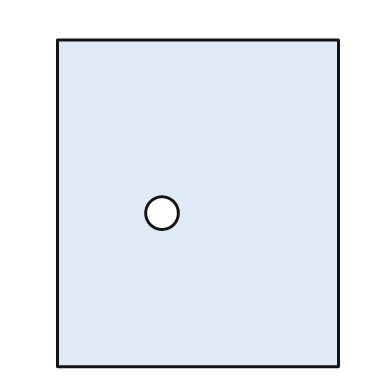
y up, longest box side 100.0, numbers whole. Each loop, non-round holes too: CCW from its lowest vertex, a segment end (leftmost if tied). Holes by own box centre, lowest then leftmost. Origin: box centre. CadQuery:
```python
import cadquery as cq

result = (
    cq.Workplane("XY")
    .moveTo(-43.0, -50.0)
    .lineTo(43.0, -50.0)
    .lineTo(43.0, 50.0)
    .lineTo(-43.0, 50.0)
    .close()
    .moveTo(-11.0, -3.0)
    .circle(5.0)
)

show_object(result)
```